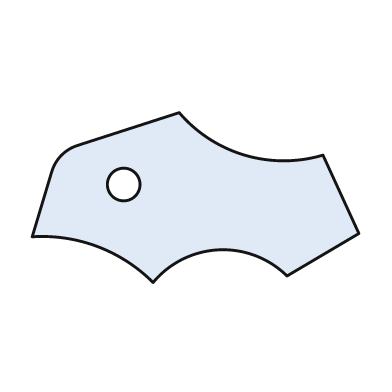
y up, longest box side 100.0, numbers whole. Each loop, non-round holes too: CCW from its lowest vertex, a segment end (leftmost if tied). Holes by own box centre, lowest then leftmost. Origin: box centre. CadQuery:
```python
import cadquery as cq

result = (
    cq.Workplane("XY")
    .moveTo(-13.0, -26.0)
    .threePointArc((7.0, -16.0), (28.0, -24.0))
    .lineTo(50.0, -11.0)
    .lineTo(39.0, 13.0)
    .threePointArc((15.0, 13.0), (-5.0, 26.0))
    .lineTo(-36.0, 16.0)
    .threePointArc((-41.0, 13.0), (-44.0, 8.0))
    .lineTo(-50.0, -12.0)
    .threePointArc((-30.0, -15.0), (-13.0, -26.0))
    .close()
    .moveTo(-22.0, 4.0)
    .circle(5.0)
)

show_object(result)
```